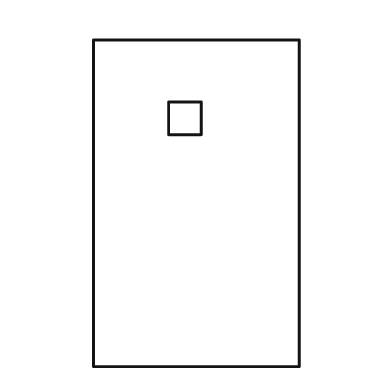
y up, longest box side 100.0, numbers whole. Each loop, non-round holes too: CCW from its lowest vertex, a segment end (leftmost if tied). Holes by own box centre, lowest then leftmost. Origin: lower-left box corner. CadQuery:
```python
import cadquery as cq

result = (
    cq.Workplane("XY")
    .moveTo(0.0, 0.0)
    .lineTo(63.0, 0.0)
    .lineTo(63.0, 100.0)
    .lineTo(0.0, 100.0)
    .close()
    .moveTo(23.0, 71.0)
    .lineTo(33.0, 71.0)
    .lineTo(33.0, 81.0)
    .lineTo(23.0, 81.0)
    .close()
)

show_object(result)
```